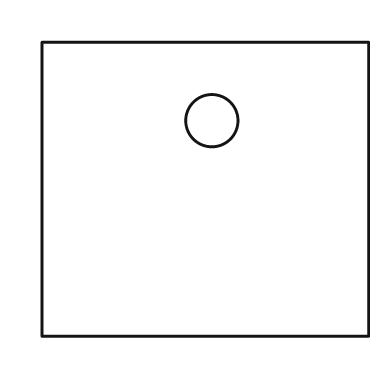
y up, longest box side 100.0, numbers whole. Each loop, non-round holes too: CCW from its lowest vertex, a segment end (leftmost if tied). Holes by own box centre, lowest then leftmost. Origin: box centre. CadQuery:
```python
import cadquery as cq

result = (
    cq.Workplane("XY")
    .moveTo(-50.0, -45.0)
    .lineTo(50.0, -45.0)
    .lineTo(50.0, 45.0)
    .lineTo(-50.0, 45.0)
    .close()
    .moveTo(2.0, 21.0)
    .circle(8.0)
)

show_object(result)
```